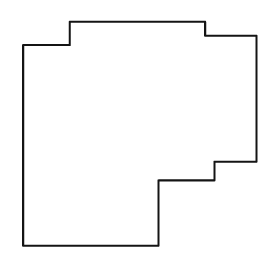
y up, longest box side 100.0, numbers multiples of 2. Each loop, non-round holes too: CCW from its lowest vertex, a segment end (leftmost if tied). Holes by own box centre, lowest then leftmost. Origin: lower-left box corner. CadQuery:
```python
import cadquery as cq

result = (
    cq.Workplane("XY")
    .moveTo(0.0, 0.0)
    .lineTo(58.0, 0.0)
    .lineTo(58.0, 28.0)
    .lineTo(82.0, 28.0)
    .lineTo(82.0, 36.0)
    .lineTo(100.0, 36.0)
    .lineTo(100.0, 90.0)
    .lineTo(78.0, 90.0)
    .lineTo(78.0, 96.0)
    .lineTo(20.0, 96.0)
    .lineTo(20.0, 86.0)
    .lineTo(0.0, 86.0)
    .close()
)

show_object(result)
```